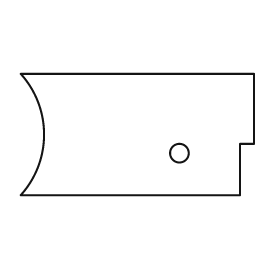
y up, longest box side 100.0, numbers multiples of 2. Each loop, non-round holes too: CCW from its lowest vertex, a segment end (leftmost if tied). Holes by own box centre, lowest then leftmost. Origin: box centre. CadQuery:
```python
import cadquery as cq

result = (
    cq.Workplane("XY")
    .moveTo(-50.0, -26.0)
    .lineTo(44.0, -26.0)
    .lineTo(44.0, -4.0)
    .lineTo(50.0, -4.0)
    .lineTo(50.0, 26.0)
    .lineTo(-50.0, 26.0)
    .threePointArc((-40.0, 0.0), (-50.0, -26.0))
    .close()
    .moveTo(18.0, -8.0)
    .circle(4.0)
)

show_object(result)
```